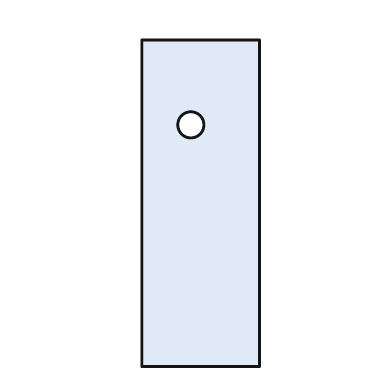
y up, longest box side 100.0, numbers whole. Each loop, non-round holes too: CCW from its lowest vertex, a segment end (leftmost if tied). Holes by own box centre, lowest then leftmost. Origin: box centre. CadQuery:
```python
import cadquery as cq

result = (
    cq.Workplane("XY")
    .moveTo(-18.0, -50.0)
    .lineTo(18.0, -50.0)
    .lineTo(18.0, 50.0)
    .lineTo(-18.0, 50.0)
    .close()
    .moveTo(-3.0, 24.0)
    .circle(4.0)
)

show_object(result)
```